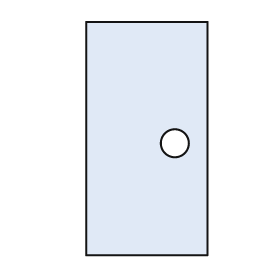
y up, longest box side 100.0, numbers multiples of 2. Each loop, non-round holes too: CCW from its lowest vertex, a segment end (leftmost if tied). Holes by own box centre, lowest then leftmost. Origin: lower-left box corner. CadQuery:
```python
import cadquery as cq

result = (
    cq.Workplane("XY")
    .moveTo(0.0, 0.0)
    .lineTo(52.0, 0.0)
    .lineTo(52.0, 100.0)
    .lineTo(0.0, 100.0)
    .close()
    .moveTo(38.0, 48.0)
    .circle(6.0)
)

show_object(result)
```